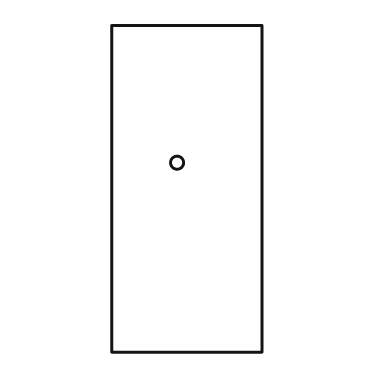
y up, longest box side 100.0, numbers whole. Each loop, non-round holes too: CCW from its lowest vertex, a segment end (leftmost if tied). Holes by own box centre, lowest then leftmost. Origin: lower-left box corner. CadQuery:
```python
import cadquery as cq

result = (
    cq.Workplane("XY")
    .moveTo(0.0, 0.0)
    .lineTo(46.0, 0.0)
    .lineTo(46.0, 100.0)
    .lineTo(0.0, 100.0)
    .close()
    .moveTo(20.0, 58.0)
    .circle(2.0)
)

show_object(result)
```